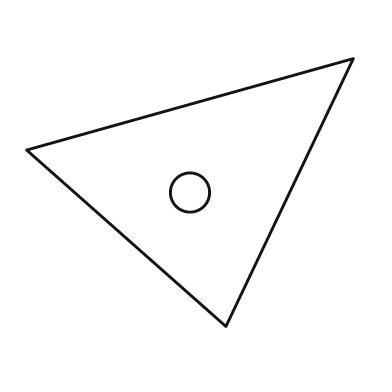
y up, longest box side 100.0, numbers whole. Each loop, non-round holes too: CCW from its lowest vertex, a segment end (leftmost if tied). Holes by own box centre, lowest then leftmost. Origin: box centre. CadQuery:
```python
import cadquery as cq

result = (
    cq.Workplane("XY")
    .moveTo(11.0, -41.0)
    .lineTo(50.0, 41.0)
    .lineTo(-50.0, 13.0)
    .close()
    .moveTo(0.0, 0.0)
    .circle(6.0)
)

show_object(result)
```